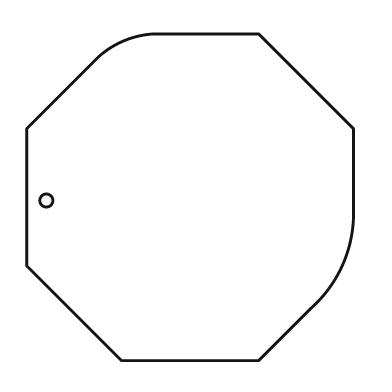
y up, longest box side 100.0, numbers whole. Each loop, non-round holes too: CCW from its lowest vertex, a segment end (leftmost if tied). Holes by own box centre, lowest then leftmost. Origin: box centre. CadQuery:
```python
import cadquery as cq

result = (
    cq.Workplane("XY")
    .moveTo(-21.0, -50.0)
    .lineTo(21.0, -50.0)
    .lineTo(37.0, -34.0)
    .threePointArc((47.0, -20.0), (50.0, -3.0))
    .lineTo(50.0, 21.0)
    .lineTo(21.0, 50.0)
    .lineTo(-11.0, 50.0)
    .threePointArc((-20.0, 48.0), (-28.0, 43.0))
    .lineTo(-50.0, 21.0)
    .lineTo(-50.0, -21.0)
    .close()
    .moveTo(-44.0, -1.0)
    .circle(2.0)
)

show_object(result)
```